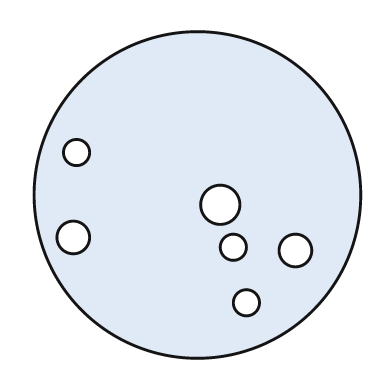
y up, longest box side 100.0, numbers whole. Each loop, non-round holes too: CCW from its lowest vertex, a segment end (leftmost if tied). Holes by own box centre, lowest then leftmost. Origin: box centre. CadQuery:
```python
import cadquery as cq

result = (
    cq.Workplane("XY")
    .moveTo(0.0, 0.0)
    .circle(50.0)
    .moveTo(15.0, -33.0)
    .circle(4.0)
    .moveTo(30.0, -17.0)
    .circle(5.0)
    .moveTo(11.0, -16.0)
    .circle(4.0)
    .moveTo(-38.0, -13.0)
    .circle(5.0)
    .moveTo(7.0, -3.0)
    .circle(6.0)
    .moveTo(-37.0, 13.0)
    .circle(4.0)
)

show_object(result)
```